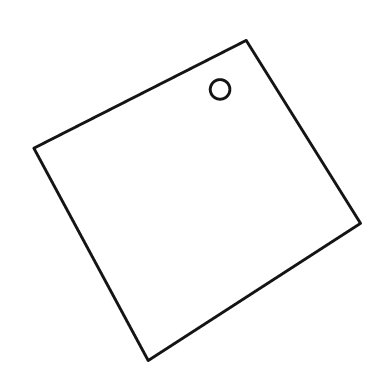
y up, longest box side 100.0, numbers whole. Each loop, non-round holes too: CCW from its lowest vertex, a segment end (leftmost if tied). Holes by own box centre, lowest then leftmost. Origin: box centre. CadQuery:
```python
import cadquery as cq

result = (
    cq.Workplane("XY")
    .moveTo(-15.0, -49.0)
    .lineTo(50.0, -7.0)
    .lineTo(15.0, 49.0)
    .lineTo(-50.0, 16.0)
    .close()
    .moveTo(7.0, 34.0)
    .circle(3.0)
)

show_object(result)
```